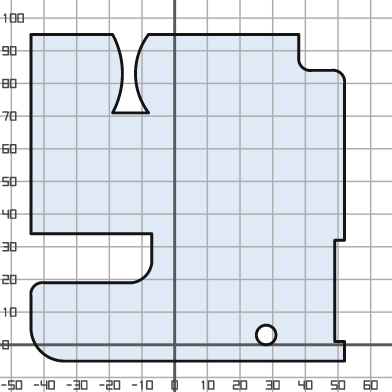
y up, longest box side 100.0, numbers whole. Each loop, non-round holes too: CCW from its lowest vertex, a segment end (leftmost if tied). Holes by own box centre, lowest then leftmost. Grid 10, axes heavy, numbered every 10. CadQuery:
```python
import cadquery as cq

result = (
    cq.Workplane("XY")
    .moveTo(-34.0, -5.0)
    .lineTo(52.0, -5.0)
    .lineTo(52.0, 1.0)
    .lineTo(49.0, 1.0)
    .lineTo(49.0, 32.0)
    .lineTo(52.0, 32.0)
    .lineTo(52.0, 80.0)
    .threePointArc((51.0, 83.0), (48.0, 84.0))
    .lineTo(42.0, 84.0)
    .threePointArc((39.0, 85.0), (38.0, 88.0))
    .lineTo(38.0, 95.0)
    .lineTo(-8.0, 95.0)
    .threePointArc((-12.0, 83.0), (-8.0, 71.0))
    .lineTo(-19.0, 71.0)
    .threePointArc((-16.0, 83.0), (-19.0, 95.0))
    .lineTo(-44.0, 95.0)
    .lineTo(-44.0, 34.0)
    .lineTo(-7.0, 34.0)
    .lineTo(-7.0, 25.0)
    .threePointArc((-9.0, 21.0), (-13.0, 19.0))
    .lineTo(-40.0, 19.0)
    .threePointArc((-43.0, 18.0), (-44.0, 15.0))
    .lineTo(-44.0, 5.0)
    .threePointArc((-41.0, -2.0), (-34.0, -5.0))
    .close()
    .moveTo(28.0, 3.0)
    .circle(3.0)
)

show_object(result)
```